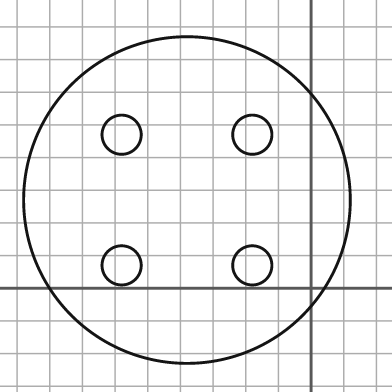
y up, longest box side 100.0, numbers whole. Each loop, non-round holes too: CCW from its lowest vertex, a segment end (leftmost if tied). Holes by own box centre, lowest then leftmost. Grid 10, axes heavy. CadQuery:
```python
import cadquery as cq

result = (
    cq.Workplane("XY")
    .moveTo(-38.0, 27.0)
    .circle(50.0)
    .moveTo(-58.0, 7.0)
    .circle(6.0)
    .moveTo(-18.0, 7.0)
    .circle(6.0)
    .moveTo(-58.0, 47.0)
    .circle(6.0)
    .moveTo(-18.0, 47.0)
    .circle(6.0)
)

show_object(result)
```